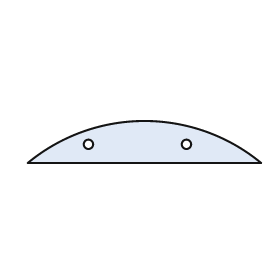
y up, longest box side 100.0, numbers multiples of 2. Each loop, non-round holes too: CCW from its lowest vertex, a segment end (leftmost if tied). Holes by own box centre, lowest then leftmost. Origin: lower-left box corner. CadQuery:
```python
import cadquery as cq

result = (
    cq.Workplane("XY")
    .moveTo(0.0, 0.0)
    .lineTo(100.0, 0.0)
    .threePointArc((50.0, 18.0), (0.0, 0.0))
    .close()
    .moveTo(26.0, 8.0)
    .circle(2.0)
    .moveTo(68.0, 8.0)
    .circle(2.0)
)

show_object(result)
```